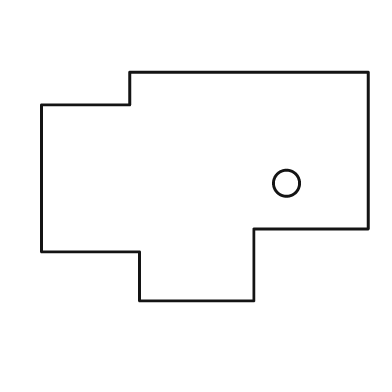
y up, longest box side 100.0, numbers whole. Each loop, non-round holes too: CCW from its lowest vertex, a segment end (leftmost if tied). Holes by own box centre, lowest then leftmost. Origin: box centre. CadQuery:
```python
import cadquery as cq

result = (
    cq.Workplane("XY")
    .moveTo(-20.0, -35.0)
    .lineTo(15.0, -35.0)
    .lineTo(15.0, -13.0)
    .lineTo(50.0, -13.0)
    .lineTo(50.0, 35.0)
    .lineTo(-23.0, 35.0)
    .lineTo(-23.0, 25.0)
    .lineTo(-50.0, 25.0)
    .lineTo(-50.0, -20.0)
    .lineTo(-20.0, -20.0)
    .close()
    .moveTo(25.0, 1.0)
    .circle(4.0)
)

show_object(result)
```